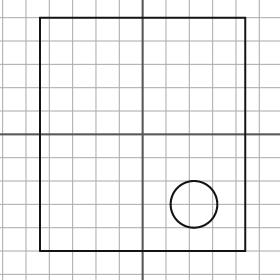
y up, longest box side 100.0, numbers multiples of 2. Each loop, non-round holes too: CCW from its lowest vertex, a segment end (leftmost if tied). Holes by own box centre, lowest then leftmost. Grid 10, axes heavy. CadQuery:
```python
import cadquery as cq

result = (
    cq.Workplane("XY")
    .moveTo(-44.0, -50.0)
    .lineTo(44.0, -50.0)
    .lineTo(44.0, 50.0)
    .lineTo(-44.0, 50.0)
    .close()
    .moveTo(22.0, -30.0)
    .circle(10.0)
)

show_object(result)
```